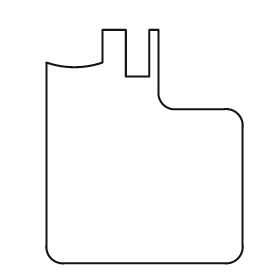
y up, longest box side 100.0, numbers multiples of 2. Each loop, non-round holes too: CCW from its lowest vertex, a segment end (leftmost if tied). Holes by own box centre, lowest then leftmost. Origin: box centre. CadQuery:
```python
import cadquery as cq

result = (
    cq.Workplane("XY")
    .moveTo(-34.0, -50.0)
    .lineTo(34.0, -50.0)
    .threePointArc((40.0, -48.0), (42.0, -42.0))
    .lineTo(42.0, 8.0)
    .threePointArc((40.0, 14.0), (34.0, 16.0))
    .lineTo(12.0, 16.0)
    .threePointArc((8.0, 18.0), (6.0, 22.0))
    .lineTo(6.0, 50.0)
    .lineTo(2.0, 50.0)
    .lineTo(2.0, 30.0)
    .lineTo(-8.0, 30.0)
    .lineTo(-8.0, 50.0)
    .lineTo(-18.0, 50.0)
    .lineTo(-18.0, 36.0)
    .threePointArc((-30.0, 34.0), (-42.0, 36.0))
    .lineTo(-42.0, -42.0)
    .threePointArc((-40.0, -48.0), (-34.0, -50.0))
    .close()
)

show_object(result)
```